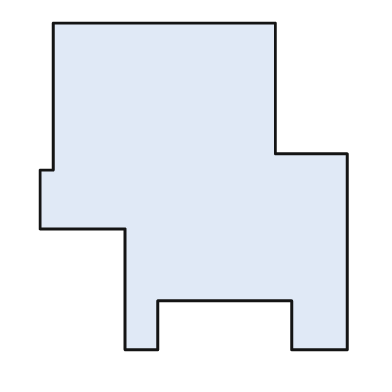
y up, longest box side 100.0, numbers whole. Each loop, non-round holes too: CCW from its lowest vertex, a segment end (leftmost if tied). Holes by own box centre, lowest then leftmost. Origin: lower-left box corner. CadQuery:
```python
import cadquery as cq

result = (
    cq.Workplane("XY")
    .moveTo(26.0, 0.0)
    .lineTo(36.0, 0.0)
    .lineTo(36.0, 15.0)
    .lineTo(77.0, 15.0)
    .lineTo(77.0, 0.0)
    .lineTo(94.0, 0.0)
    .lineTo(94.0, 60.0)
    .lineTo(72.0, 60.0)
    .lineTo(72.0, 100.0)
    .lineTo(4.0, 100.0)
    .lineTo(4.0, 55.0)
    .lineTo(0.0, 55.0)
    .lineTo(0.0, 37.0)
    .lineTo(26.0, 37.0)
    .close()
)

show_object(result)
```